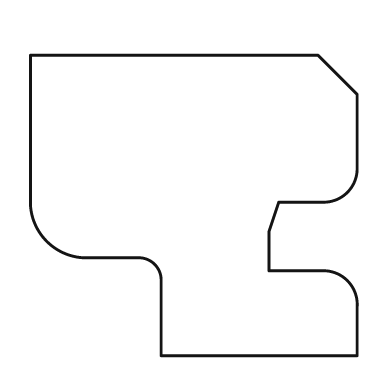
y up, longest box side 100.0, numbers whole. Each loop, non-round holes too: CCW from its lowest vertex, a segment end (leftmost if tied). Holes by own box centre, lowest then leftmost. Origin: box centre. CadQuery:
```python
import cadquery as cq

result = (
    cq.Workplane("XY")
    .moveTo(-10.0, -46.0)
    .lineTo(50.0, -46.0)
    .lineTo(50.0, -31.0)
    .threePointArc((47.0, -23.0), (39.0, -20.0))
    .lineTo(23.0, -20.0)
    .lineTo(23.0, -8.0)
    .lineTo(26.0, 1.0)
    .lineTo(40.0, 1.0)
    .threePointArc((47.0, 4.0), (50.0, 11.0))
    .lineTo(50.0, 34.0)
    .lineTo(38.0, 46.0)
    .lineTo(-50.0, 46.0)
    .lineTo(-50.0, 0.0)
    .threePointArc((-45.0, -11.0), (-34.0, -16.0))
    .lineTo(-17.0, -16.0)
    .threePointArc((-12.0, -18.0), (-10.0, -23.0))
    .close()
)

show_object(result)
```